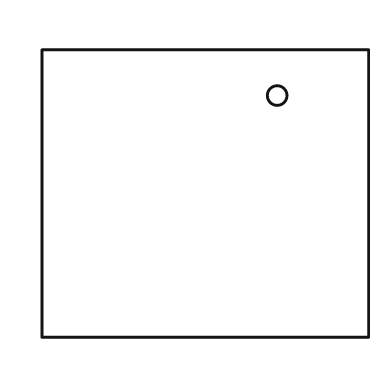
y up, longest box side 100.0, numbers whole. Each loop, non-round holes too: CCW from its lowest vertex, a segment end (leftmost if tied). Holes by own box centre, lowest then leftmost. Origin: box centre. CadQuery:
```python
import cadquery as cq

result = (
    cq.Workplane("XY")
    .moveTo(-50.0, -44.0)
    .lineTo(50.0, -44.0)
    .lineTo(50.0, 44.0)
    .lineTo(-50.0, 44.0)
    .close()
    .moveTo(22.0, 30.0)
    .circle(3.0)
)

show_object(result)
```